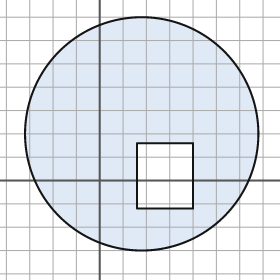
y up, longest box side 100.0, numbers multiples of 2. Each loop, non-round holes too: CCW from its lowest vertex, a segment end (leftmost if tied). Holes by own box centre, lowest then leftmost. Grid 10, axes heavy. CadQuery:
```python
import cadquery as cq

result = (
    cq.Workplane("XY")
    .moveTo(18.0, 20.0)
    .circle(50.0)
    .moveTo(16.0, -12.0)
    .lineTo(40.0, -12.0)
    .lineTo(40.0, 16.0)
    .lineTo(16.0, 16.0)
    .close()
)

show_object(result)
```